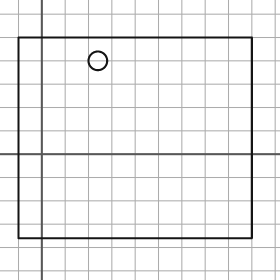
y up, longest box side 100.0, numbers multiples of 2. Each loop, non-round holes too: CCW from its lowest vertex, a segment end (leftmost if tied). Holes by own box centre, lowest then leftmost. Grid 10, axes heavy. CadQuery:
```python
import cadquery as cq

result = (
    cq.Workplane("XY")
    .moveTo(-10.0, -36.0)
    .lineTo(90.0, -36.0)
    .lineTo(90.0, 50.0)
    .lineTo(-10.0, 50.0)
    .close()
    .moveTo(24.0, 40.0)
    .circle(4.0)
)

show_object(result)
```